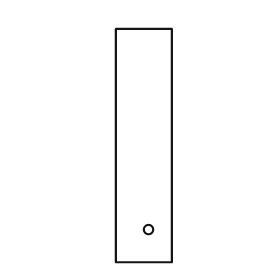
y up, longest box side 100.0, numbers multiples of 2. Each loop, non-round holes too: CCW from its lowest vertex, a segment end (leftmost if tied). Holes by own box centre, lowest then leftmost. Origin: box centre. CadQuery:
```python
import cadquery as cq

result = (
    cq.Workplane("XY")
    .moveTo(-12.0, -50.0)
    .lineTo(12.0, -50.0)
    .lineTo(12.0, 50.0)
    .lineTo(-12.0, 50.0)
    .close()
    .moveTo(2.0, -36.0)
    .circle(2.0)
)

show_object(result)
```